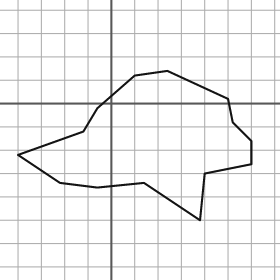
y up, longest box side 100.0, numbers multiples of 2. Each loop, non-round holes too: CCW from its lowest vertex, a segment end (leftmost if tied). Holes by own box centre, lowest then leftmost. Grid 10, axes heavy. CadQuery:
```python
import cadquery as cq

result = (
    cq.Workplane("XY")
    .moveTo(38.0, -50.0)
    .lineTo(40.0, -30.0)
    .lineTo(60.0, -26.0)
    .lineTo(60.0, -16.0)
    .lineTo(52.0, -8.0)
    .lineTo(50.0, 2.0)
    .lineTo(24.0, 14.0)
    .lineTo(10.0, 12.0)
    .lineTo(-6.0, -2.0)
    .lineTo(-12.0, -12.0)
    .lineTo(-40.0, -22.0)
    .lineTo(-22.0, -34.0)
    .lineTo(-6.0, -36.0)
    .lineTo(14.0, -34.0)
    .close()
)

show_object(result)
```